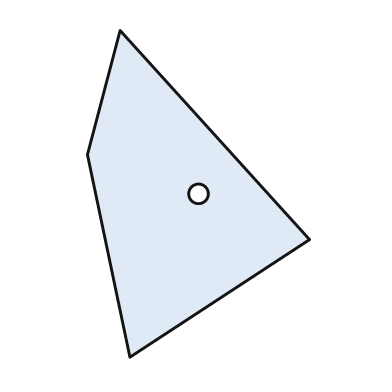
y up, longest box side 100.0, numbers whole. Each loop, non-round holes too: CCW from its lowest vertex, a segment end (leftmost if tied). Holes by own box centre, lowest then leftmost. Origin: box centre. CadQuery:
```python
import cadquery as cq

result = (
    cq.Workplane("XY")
    .moveTo(-21.0, -50.0)
    .lineTo(34.0, -14.0)
    .lineTo(-24.0, 50.0)
    .lineTo(-34.0, 12.0)
    .close()
    .moveTo(0.0, 0.0)
    .circle(3.0)
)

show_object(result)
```